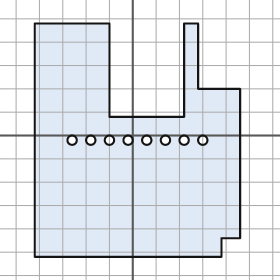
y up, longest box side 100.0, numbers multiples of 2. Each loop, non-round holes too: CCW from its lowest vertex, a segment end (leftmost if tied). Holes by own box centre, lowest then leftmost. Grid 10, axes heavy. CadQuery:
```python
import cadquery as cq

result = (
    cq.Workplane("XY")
    .moveTo(-42.0, -52.0)
    .lineTo(38.0, -52.0)
    .lineTo(38.0, -44.0)
    .lineTo(46.0, -44.0)
    .lineTo(46.0, 20.0)
    .lineTo(28.0, 20.0)
    .lineTo(28.0, 48.0)
    .lineTo(22.0, 48.0)
    .lineTo(22.0, 8.0)
    .lineTo(-10.0, 8.0)
    .lineTo(-10.0, 48.0)
    .lineTo(-42.0, 48.0)
    .close()
    .moveTo(-26.0, -2.0)
    .circle(2.0)
    .moveTo(-18.0, -2.0)
    .circle(2.0)
    .moveTo(-10.0, -2.0)
    .circle(2.0)
    .moveTo(-2.0, -2.0)
    .circle(2.0)
    .moveTo(6.0, -2.0)
    .circle(2.0)
    .moveTo(14.0, -2.0)
    .circle(2.0)
    .moveTo(22.0, -2.0)
    .circle(2.0)
    .moveTo(30.0, -2.0)
    .circle(2.0)
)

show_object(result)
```